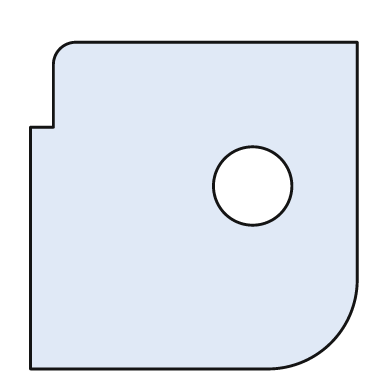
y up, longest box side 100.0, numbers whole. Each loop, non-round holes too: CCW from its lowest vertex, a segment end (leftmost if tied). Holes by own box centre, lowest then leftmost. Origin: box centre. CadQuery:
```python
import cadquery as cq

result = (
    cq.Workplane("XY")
    .moveTo(-50.0, -50.0)
    .lineTo(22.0, -50.0)
    .threePointArc((42.0, -42.0), (50.0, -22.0))
    .lineTo(50.0, 50.0)
    .lineTo(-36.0, 50.0)
    .threePointArc((-41.0, 48.0), (-43.0, 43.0))
    .lineTo(-43.0, 24.0)
    .lineTo(-50.0, 24.0)
    .close()
    .moveTo(18.0, 6.0)
    .circle(12.0)
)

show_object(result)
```